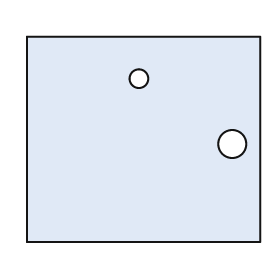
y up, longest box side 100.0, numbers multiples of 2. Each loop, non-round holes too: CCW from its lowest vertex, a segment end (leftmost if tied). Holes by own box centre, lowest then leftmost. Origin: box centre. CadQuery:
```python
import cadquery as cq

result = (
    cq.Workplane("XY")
    .moveTo(-50.0, -44.0)
    .lineTo(50.0, -44.0)
    .lineTo(50.0, 44.0)
    .lineTo(-50.0, 44.0)
    .close()
    .moveTo(38.0, -2.0)
    .circle(6.0)
    .moveTo(-2.0, 26.0)
    .circle(4.0)
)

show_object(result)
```